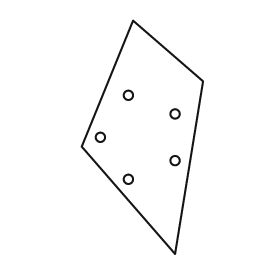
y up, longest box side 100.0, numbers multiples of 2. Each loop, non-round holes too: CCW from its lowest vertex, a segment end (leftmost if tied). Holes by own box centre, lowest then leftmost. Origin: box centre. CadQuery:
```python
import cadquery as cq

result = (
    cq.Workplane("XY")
    .moveTo(14.0, -50.0)
    .lineTo(26.0, 24.0)
    .lineTo(-4.0, 50.0)
    .lineTo(-26.0, -4.0)
    .close()
    .moveTo(-6.0, -18.0)
    .circle(2.0)
    .moveTo(14.0, -10.0)
    .circle(2.0)
    .moveTo(-18.0, 0.0)
    .circle(2.0)
    .moveTo(14.0, 10.0)
    .circle(2.0)
    .moveTo(-6.0, 18.0)
    .circle(2.0)
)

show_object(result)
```